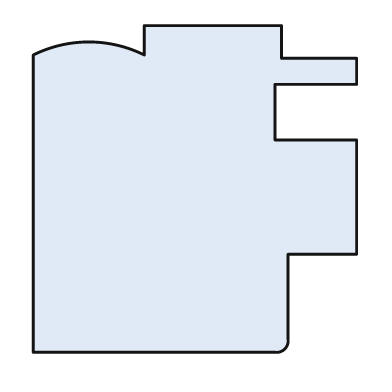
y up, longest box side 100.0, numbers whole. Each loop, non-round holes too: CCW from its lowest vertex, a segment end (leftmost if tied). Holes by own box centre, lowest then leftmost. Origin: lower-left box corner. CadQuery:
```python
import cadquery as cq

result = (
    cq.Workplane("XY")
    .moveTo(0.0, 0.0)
    .lineTo(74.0, 0.0)
    .threePointArc((77.0, 1.0), (78.0, 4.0))
    .lineTo(78.0, 30.0)
    .lineTo(99.0, 30.0)
    .lineTo(99.0, 65.0)
    .lineTo(74.0, 65.0)
    .lineTo(74.0, 82.0)
    .lineTo(99.0, 82.0)
    .lineTo(99.0, 90.0)
    .lineTo(76.0, 90.0)
    .lineTo(76.0, 100.0)
    .lineTo(34.0, 100.0)
    .lineTo(34.0, 91.0)
    .threePointArc((17.0, 95.0), (0.0, 91.0))
    .close()
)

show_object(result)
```